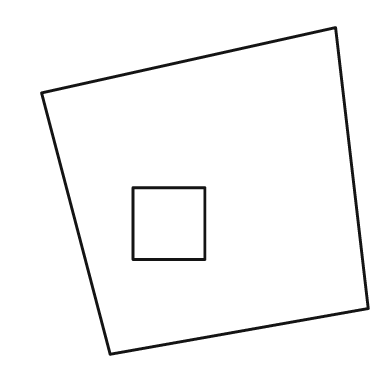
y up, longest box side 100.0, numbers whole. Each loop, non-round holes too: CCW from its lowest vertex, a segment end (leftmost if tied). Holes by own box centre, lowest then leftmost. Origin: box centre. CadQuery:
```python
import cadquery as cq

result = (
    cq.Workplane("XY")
    .moveTo(-29.0, -50.0)
    .lineTo(50.0, -36.0)
    .lineTo(40.0, 50.0)
    .lineTo(-50.0, 30.0)
    .close()
    .moveTo(-22.0, -21.0)
    .lineTo(0.0, -21.0)
    .lineTo(0.0, 1.0)
    .lineTo(-22.0, 1.0)
    .close()
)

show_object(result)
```